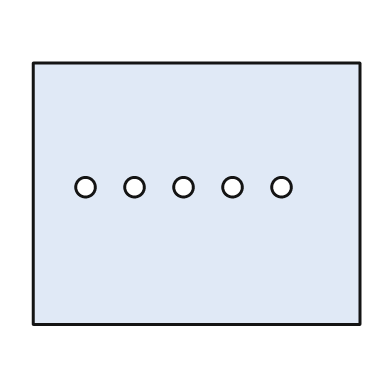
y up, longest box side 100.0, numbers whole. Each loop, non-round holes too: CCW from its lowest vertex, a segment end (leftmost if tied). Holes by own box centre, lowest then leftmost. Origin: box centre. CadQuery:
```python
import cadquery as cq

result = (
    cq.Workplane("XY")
    .moveTo(-50.0, -40.0)
    .lineTo(50.0, -40.0)
    .lineTo(50.0, 40.0)
    .lineTo(-50.0, 40.0)
    .close()
    .moveTo(-34.0, 2.0)
    .circle(3.0)
    .moveTo(-19.0, 2.0)
    .circle(3.0)
    .moveTo(-4.0, 2.0)
    .circle(3.0)
    .moveTo(11.0, 2.0)
    .circle(3.0)
    .moveTo(26.0, 2.0)
    .circle(3.0)
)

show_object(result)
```